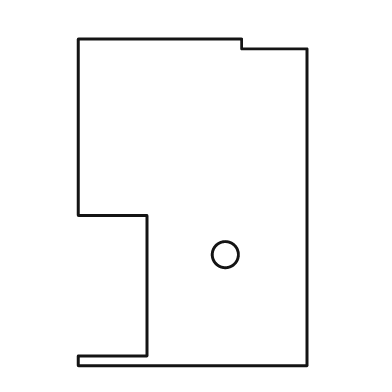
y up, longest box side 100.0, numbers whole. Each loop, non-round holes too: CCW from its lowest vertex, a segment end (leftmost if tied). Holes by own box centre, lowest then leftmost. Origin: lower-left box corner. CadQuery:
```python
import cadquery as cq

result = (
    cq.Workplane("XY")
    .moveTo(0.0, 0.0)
    .lineTo(70.0, 0.0)
    .lineTo(70.0, 97.0)
    .lineTo(50.0, 97.0)
    .lineTo(50.0, 100.0)
    .lineTo(0.0, 100.0)
    .lineTo(0.0, 46.0)
    .lineTo(21.0, 46.0)
    .lineTo(21.0, 3.0)
    .lineTo(0.0, 3.0)
    .close()
    .moveTo(45.0, 34.0)
    .circle(4.0)
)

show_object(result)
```